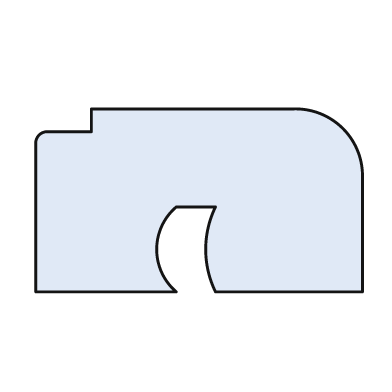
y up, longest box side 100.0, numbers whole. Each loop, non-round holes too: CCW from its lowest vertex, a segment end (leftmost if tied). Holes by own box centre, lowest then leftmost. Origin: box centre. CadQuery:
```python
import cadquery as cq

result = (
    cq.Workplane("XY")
    .moveTo(-50.0, -28.0)
    .lineTo(-7.0, -28.0)
    .threePointArc((-13.0, -15.0), (-7.0, -2.0))
    .lineTo(5.0, -2.0)
    .threePointArc((2.0, -15.0), (5.0, -28.0))
    .lineTo(50.0, -28.0)
    .lineTo(50.0, 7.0)
    .threePointArc((44.0, 22.0), (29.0, 28.0))
    .lineTo(-33.0, 28.0)
    .lineTo(-33.0, 21.0)
    .lineTo(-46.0, 21.0)
    .threePointArc((-49.0, 20.0), (-50.0, 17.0))
    .close()
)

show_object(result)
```